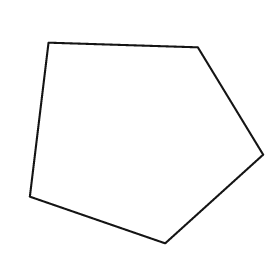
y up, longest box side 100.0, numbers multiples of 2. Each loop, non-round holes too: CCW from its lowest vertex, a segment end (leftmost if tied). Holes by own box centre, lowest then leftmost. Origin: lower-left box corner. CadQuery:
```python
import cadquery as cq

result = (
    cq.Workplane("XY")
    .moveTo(58.0, 0.0)
    .lineTo(100.0, 38.0)
    .lineTo(72.0, 84.0)
    .lineTo(8.0, 86.0)
    .lineTo(0.0, 20.0)
    .close()
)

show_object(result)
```